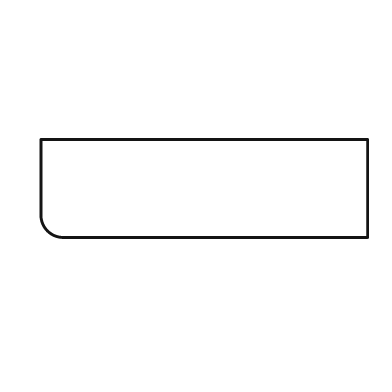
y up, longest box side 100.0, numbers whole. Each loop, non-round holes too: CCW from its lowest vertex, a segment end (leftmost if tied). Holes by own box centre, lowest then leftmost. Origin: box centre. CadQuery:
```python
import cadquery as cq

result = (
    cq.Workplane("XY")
    .moveTo(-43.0, -15.0)
    .lineTo(50.0, -15.0)
    .lineTo(50.0, 15.0)
    .lineTo(-50.0, 15.0)
    .lineTo(-50.0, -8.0)
    .threePointArc((-48.0, -13.0), (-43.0, -15.0))
    .close()
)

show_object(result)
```